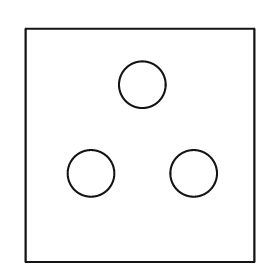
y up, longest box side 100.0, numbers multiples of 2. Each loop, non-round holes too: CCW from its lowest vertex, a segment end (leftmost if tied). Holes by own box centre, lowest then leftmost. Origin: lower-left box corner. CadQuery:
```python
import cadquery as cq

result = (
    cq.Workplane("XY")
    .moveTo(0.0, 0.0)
    .lineTo(98.0, 0.0)
    .lineTo(98.0, 100.0)
    .lineTo(0.0, 100.0)
    .close()
    .moveTo(28.0, 38.0)
    .circle(10.0)
    .moveTo(72.0, 38.0)
    .circle(10.0)
    .moveTo(50.0, 76.0)
    .circle(10.0)
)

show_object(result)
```